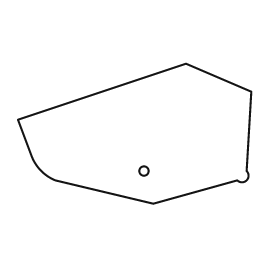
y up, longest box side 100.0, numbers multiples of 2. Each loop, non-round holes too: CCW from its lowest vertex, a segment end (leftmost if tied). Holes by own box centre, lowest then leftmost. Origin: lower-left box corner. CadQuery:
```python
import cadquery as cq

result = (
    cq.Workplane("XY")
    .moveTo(58.0, 0.0)
    .lineTo(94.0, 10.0)
    .threePointArc((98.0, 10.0), (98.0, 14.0))
    .lineTo(100.0, 48.0)
    .lineTo(72.0, 60.0)
    .lineTo(0.0, 36.0)
    .lineTo(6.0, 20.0)
    .threePointArc((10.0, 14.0), (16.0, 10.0))
    .close()
    .moveTo(54.0, 14.0)
    .circle(2.0)
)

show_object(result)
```